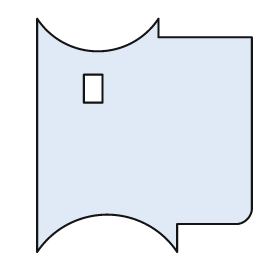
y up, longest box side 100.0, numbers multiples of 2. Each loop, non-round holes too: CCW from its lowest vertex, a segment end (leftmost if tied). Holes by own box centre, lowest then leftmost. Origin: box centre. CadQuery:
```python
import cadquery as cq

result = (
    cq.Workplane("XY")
    .moveTo(-46.0, -50.0)
    .threePointArc((-16.0, -34.0), (14.0, -50.0))
    .lineTo(14.0, -38.0)
    .lineTo(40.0, -38.0)
    .threePointArc((44.0, -36.0), (46.0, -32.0))
    .lineTo(46.0, 42.0)
    .lineTo(6.0, 42.0)
    .lineTo(6.0, 50.0)
    .threePointArc((-20.0, 36.0), (-46.0, 50.0))
    .close()
    .moveTo(-26.0, 14.0)
    .lineTo(-18.0, 14.0)
    .lineTo(-18.0, 26.0)
    .lineTo(-26.0, 26.0)
    .close()
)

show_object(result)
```